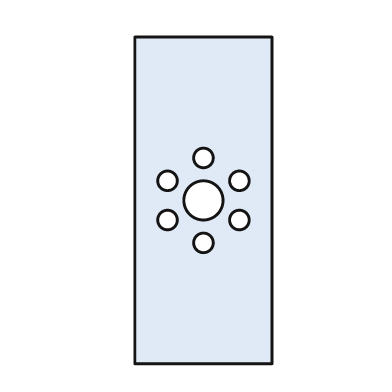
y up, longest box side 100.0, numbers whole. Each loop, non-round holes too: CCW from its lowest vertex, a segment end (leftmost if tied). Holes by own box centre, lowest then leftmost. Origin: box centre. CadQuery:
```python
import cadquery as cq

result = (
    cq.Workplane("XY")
    .moveTo(-21.0, -50.0)
    .lineTo(21.0, -50.0)
    .lineTo(21.0, 50.0)
    .lineTo(-21.0, 50.0)
    .close()
    .moveTo(0.0, -13.0)
    .circle(3.0)
    .moveTo(-11.0, -6.0)
    .circle(3.0)
    .moveTo(11.0, -6.0)
    .circle(3.0)
    .moveTo(0.0, 0.0)
    .circle(6.0)
    .moveTo(-11.0, 6.0)
    .circle(3.0)
    .moveTo(11.0, 6.0)
    .circle(3.0)
    .moveTo(0.0, 13.0)
    .circle(3.0)
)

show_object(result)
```